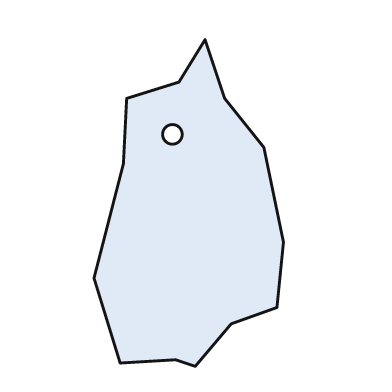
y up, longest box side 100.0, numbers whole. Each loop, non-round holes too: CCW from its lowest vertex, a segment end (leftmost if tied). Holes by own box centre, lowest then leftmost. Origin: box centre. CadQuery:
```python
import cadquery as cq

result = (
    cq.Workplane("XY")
    .moveTo(2.0, -50.0)
    .lineTo(13.0, -37.0)
    .lineTo(27.0, -32.0)
    .lineTo(29.0, -12.0)
    .lineTo(23.0, 17.0)
    .lineTo(11.0, 32.0)
    .lineTo(5.0, 50.0)
    .lineTo(-3.0, 37.0)
    .lineTo(-19.0, 32.0)
    .lineTo(-20.0, 12.0)
    .lineTo(-29.0, -23.0)
    .lineTo(-21.0, -49.0)
    .lineTo(-4.0, -48.0)
    .close()
    .moveTo(-5.0, 21.0)
    .circle(3.0)
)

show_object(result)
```